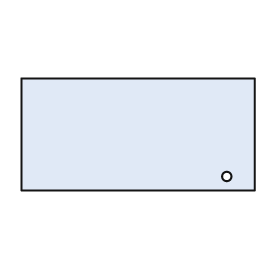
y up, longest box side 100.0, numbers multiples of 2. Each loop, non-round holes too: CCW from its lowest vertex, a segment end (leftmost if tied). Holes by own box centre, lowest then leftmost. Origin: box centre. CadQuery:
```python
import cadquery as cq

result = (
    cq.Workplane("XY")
    .moveTo(-50.0, -24.0)
    .lineTo(50.0, -24.0)
    .lineTo(50.0, 24.0)
    .lineTo(-50.0, 24.0)
    .close()
    .moveTo(38.0, -18.0)
    .circle(2.0)
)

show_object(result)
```